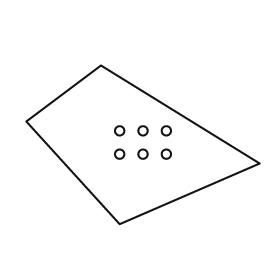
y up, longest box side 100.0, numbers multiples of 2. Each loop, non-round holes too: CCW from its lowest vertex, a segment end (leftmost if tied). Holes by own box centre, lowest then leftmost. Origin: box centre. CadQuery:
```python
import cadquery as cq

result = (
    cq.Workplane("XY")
    .moveTo(-10.0, -34.0)
    .lineTo(50.0, -8.0)
    .lineTo(-18.0, 34.0)
    .lineTo(-50.0, 10.0)
    .close()
    .moveTo(-10.0, -4.0)
    .circle(2.0)
    .moveTo(0.0, -4.0)
    .circle(2.0)
    .moveTo(10.0, -4.0)
    .circle(2.0)
    .moveTo(-10.0, 6.0)
    .circle(2.0)
    .moveTo(0.0, 6.0)
    .circle(2.0)
    .moveTo(10.0, 6.0)
    .circle(2.0)
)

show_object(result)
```